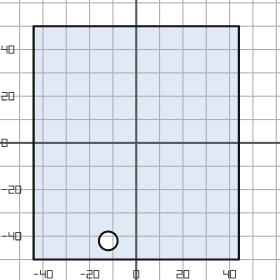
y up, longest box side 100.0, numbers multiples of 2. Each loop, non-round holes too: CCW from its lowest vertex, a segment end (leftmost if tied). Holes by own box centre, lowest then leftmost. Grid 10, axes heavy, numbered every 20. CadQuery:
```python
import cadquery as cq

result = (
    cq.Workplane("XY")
    .moveTo(-44.0, -50.0)
    .lineTo(44.0, -50.0)
    .lineTo(44.0, 50.0)
    .lineTo(-44.0, 50.0)
    .close()
    .moveTo(-12.0, -42.0)
    .circle(4.0)
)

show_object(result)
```